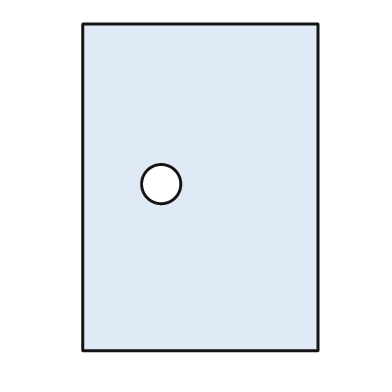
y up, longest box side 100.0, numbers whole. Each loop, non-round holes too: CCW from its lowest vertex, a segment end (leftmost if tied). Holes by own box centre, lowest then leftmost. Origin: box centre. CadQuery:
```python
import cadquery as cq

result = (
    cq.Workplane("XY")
    .moveTo(-36.0, -50.0)
    .lineTo(36.0, -50.0)
    .lineTo(36.0, 50.0)
    .lineTo(-36.0, 50.0)
    .close()
    .moveTo(-12.0, 1.0)
    .circle(6.0)
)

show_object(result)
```